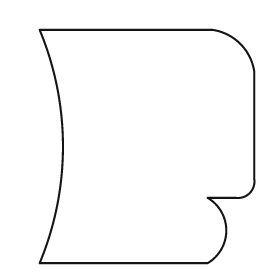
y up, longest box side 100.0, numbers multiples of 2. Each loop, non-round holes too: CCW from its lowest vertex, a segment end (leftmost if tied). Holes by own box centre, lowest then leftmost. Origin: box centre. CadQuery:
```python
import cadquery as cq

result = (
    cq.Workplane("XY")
    .moveTo(-46.0, -50.0)
    .lineTo(26.0, -50.0)
    .threePointArc((34.0, -36.0), (26.0, -22.0))
    .lineTo(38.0, -22.0)
    .threePointArc((44.0, -20.0), (46.0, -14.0))
    .lineTo(46.0, 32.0)
    .threePointArc((40.0, 44.0), (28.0, 50.0))
    .lineTo(-46.0, 50.0)
    .threePointArc((-36.0, 0.0), (-46.0, -50.0))
    .close()
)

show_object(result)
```